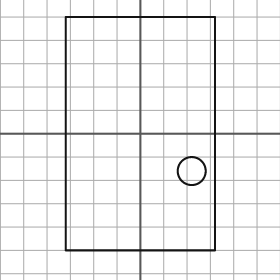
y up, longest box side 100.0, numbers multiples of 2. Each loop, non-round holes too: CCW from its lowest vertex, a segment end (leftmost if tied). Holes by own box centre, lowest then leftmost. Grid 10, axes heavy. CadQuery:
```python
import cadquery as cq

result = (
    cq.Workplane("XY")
    .moveTo(-32.0, -50.0)
    .lineTo(32.0, -50.0)
    .lineTo(32.0, 50.0)
    .lineTo(-32.0, 50.0)
    .close()
    .moveTo(22.0, -16.0)
    .circle(6.0)
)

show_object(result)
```